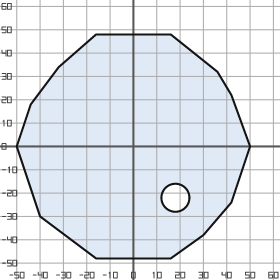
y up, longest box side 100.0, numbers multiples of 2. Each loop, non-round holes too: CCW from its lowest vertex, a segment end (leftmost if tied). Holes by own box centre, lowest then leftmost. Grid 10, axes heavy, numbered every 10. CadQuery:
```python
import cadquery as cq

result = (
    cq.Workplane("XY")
    .moveTo(-16.0, -48.0)
    .lineTo(16.0, -48.0)
    .lineTo(30.0, -38.0)
    .lineTo(42.0, -24.0)
    .lineTo(50.0, 0.0)
    .lineTo(42.0, 22.0)
    .lineTo(36.0, 32.0)
    .lineTo(16.0, 48.0)
    .lineTo(-16.0, 48.0)
    .lineTo(-32.0, 34.0)
    .lineTo(-44.0, 18.0)
    .lineTo(-50.0, 0.0)
    .lineTo(-40.0, -30.0)
    .close()
    .moveTo(18.0, -22.0)
    .circle(6.0)
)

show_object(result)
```